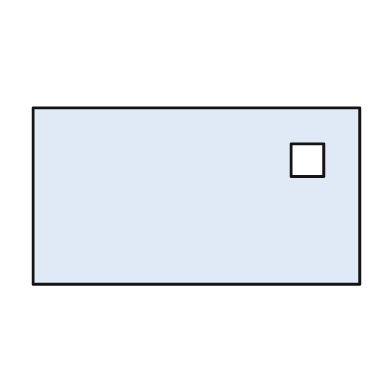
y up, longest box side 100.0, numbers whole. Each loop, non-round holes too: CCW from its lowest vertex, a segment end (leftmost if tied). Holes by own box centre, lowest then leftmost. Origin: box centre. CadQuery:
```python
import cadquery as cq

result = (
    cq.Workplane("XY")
    .moveTo(-50.0, -27.0)
    .lineTo(50.0, -27.0)
    .lineTo(50.0, 27.0)
    .lineTo(-50.0, 27.0)
    .close()
    .moveTo(29.0, 6.0)
    .lineTo(39.0, 6.0)
    .lineTo(39.0, 16.0)
    .lineTo(29.0, 16.0)
    .close()
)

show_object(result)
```